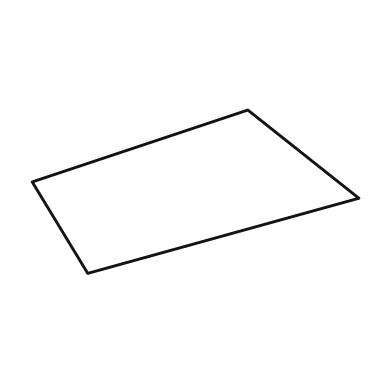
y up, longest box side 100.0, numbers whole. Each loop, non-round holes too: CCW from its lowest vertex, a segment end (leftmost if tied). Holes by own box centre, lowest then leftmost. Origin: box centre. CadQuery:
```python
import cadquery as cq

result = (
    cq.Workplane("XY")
    .moveTo(-33.0, -25.0)
    .lineTo(50.0, -2.0)
    .lineTo(16.0, 25.0)
    .lineTo(-50.0, 3.0)
    .close()
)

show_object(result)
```